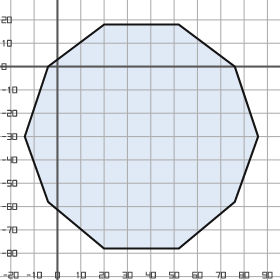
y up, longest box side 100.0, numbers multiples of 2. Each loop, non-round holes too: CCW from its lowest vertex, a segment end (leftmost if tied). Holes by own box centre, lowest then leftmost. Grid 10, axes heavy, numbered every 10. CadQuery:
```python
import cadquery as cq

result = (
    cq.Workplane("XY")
    .moveTo(20.0, -78.0)
    .lineTo(52.0, -78.0)
    .lineTo(76.0, -58.0)
    .lineTo(86.0, -30.0)
    .lineTo(76.0, 0.0)
    .lineTo(52.0, 18.0)
    .lineTo(20.0, 18.0)
    .lineTo(-4.0, 0.0)
    .lineTo(-14.0, -30.0)
    .lineTo(-4.0, -58.0)
    .close()
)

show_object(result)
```